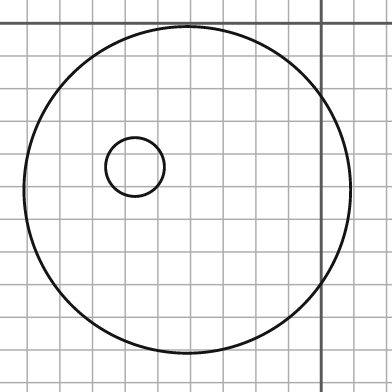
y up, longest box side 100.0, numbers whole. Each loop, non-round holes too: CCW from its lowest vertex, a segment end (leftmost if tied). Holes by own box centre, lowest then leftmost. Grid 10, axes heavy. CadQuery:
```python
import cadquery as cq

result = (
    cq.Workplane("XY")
    .moveTo(-41.0, -51.0)
    .circle(50.0)
    .moveTo(-57.0, -44.0)
    .circle(9.0)
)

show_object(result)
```